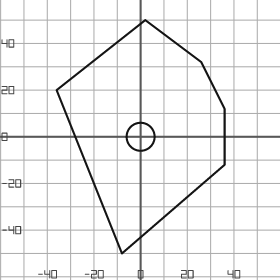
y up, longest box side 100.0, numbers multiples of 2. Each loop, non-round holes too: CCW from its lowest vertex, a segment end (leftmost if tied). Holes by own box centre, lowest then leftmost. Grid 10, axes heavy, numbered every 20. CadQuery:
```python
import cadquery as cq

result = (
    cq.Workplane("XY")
    .moveTo(-8.0, -50.0)
    .lineTo(36.0, -12.0)
    .lineTo(36.0, 12.0)
    .lineTo(26.0, 32.0)
    .lineTo(2.0, 50.0)
    .lineTo(-36.0, 20.0)
    .close()
    .moveTo(0.0, 0.0)
    .circle(6.0)
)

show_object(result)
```